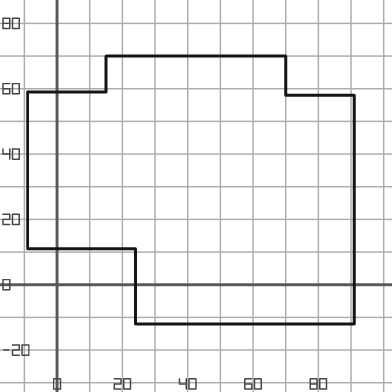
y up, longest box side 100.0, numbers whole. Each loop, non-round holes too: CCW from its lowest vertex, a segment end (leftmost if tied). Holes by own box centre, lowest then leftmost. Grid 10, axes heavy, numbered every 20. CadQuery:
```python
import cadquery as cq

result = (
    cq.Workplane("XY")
    .moveTo(24.0, -12.0)
    .lineTo(91.0, -12.0)
    .lineTo(91.0, 58.0)
    .lineTo(70.0, 58.0)
    .lineTo(70.0, 70.0)
    .lineTo(15.0, 70.0)
    .lineTo(15.0, 59.0)
    .lineTo(-9.0, 59.0)
    .lineTo(-9.0, 11.0)
    .lineTo(24.0, 11.0)
    .close()
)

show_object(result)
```